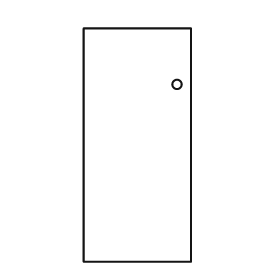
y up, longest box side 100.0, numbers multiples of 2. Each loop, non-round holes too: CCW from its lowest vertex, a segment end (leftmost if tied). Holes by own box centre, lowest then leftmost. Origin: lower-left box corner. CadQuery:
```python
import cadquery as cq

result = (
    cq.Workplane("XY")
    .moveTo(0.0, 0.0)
    .lineTo(46.0, 0.0)
    .lineTo(46.0, 100.0)
    .lineTo(0.0, 100.0)
    .close()
    .moveTo(40.0, 76.0)
    .circle(2.0)
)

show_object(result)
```